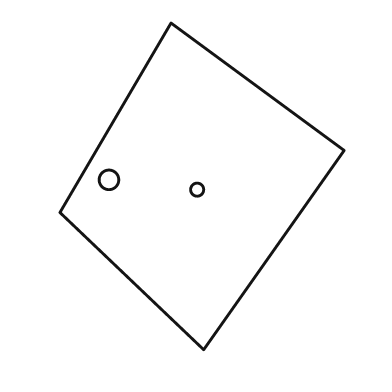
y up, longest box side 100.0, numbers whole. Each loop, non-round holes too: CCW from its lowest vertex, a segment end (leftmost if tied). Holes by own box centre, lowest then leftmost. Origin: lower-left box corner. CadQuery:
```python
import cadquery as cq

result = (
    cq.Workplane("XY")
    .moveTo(44.0, 0.0)
    .lineTo(87.0, 61.0)
    .lineTo(34.0, 100.0)
    .lineTo(0.0, 42.0)
    .close()
    .moveTo(42.0, 49.0)
    .circle(2.0)
    .moveTo(15.0, 52.0)
    .circle(3.0)
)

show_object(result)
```